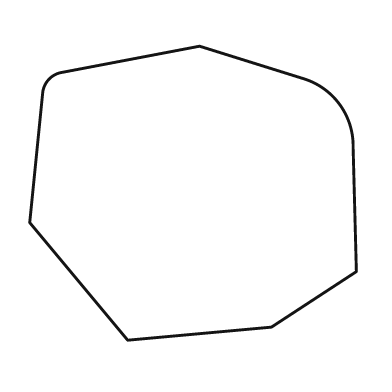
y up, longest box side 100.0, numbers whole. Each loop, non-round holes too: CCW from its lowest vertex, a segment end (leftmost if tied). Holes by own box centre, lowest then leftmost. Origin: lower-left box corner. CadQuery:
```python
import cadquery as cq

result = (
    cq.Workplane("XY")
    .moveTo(30.0, 0.0)
    .lineTo(74.0, 4.0)
    .lineTo(100.0, 21.0)
    .lineTo(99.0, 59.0)
    .threePointArc((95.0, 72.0), (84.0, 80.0))
    .lineTo(52.0, 90.0)
    .lineTo(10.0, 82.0)
    .threePointArc((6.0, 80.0), (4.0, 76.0))
    .lineTo(0.0, 36.0)
    .close()
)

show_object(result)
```